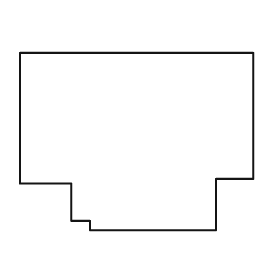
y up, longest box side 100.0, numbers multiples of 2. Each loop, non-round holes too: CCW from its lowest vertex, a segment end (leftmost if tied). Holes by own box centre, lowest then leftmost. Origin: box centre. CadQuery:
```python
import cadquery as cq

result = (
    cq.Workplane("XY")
    .moveTo(-20.0, -38.0)
    .lineTo(34.0, -38.0)
    .lineTo(34.0, -16.0)
    .lineTo(50.0, -16.0)
    .lineTo(50.0, 38.0)
    .lineTo(-50.0, 38.0)
    .lineTo(-50.0, -18.0)
    .lineTo(-28.0, -18.0)
    .lineTo(-28.0, -34.0)
    .lineTo(-20.0, -34.0)
    .close()
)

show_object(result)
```